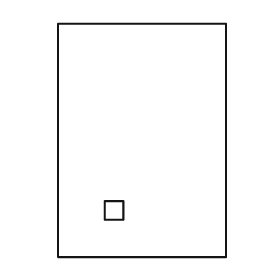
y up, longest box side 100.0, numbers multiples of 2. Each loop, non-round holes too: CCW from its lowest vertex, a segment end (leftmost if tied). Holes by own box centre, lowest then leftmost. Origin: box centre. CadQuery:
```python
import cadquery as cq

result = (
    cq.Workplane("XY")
    .moveTo(-36.0, -50.0)
    .lineTo(36.0, -50.0)
    .lineTo(36.0, 50.0)
    .lineTo(-36.0, 50.0)
    .close()
    .moveTo(-16.0, -34.0)
    .lineTo(-8.0, -34.0)
    .lineTo(-8.0, -26.0)
    .lineTo(-16.0, -26.0)
    .close()
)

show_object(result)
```